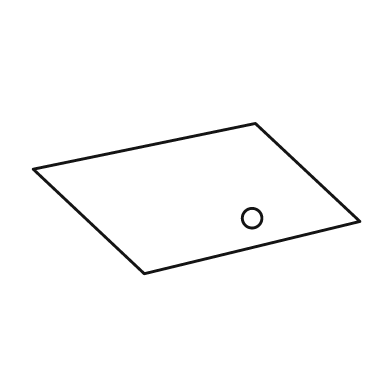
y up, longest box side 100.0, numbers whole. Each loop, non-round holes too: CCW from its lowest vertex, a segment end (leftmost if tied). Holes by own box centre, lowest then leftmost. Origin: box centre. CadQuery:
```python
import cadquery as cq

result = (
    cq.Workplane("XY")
    .moveTo(-16.0, -23.0)
    .lineTo(50.0, -7.0)
    .lineTo(18.0, 23.0)
    .lineTo(-50.0, 9.0)
    .close()
    .moveTo(17.0, -6.0)
    .circle(3.0)
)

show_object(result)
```